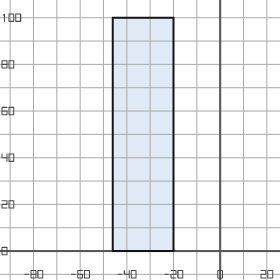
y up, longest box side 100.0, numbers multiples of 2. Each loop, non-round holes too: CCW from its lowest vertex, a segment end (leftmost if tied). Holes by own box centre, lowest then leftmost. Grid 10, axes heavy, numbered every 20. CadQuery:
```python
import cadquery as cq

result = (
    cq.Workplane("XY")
    .moveTo(-46.0, 0.0)
    .lineTo(-20.0, 0.0)
    .lineTo(-20.0, 100.0)
    .lineTo(-46.0, 100.0)
    .close()
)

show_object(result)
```